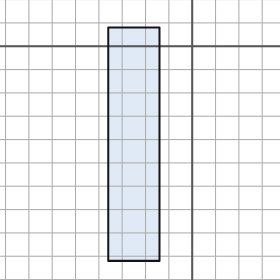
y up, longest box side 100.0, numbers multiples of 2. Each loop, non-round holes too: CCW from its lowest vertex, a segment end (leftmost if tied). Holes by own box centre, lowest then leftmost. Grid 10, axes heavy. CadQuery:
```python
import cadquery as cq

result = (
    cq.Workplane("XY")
    .moveTo(-36.0, -92.0)
    .lineTo(-14.0, -92.0)
    .lineTo(-14.0, 8.0)
    .lineTo(-36.0, 8.0)
    .close()
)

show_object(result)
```